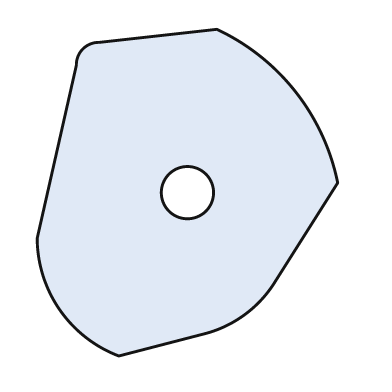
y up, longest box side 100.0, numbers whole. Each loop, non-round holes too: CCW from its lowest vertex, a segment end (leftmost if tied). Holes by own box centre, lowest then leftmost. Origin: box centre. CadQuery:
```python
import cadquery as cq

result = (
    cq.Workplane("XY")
    .moveTo(-21.0, -50.0)
    .lineTo(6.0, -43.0)
    .threePointArc((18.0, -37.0), (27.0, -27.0))
    .lineTo(46.0, 3.0)
    .threePointArc((33.0, 31.0), (9.0, 50.0))
    .lineTo(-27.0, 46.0)
    .threePointArc((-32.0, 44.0), (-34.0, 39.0))
    .lineTo(-46.0, -14.0)
    .threePointArc((-39.0, -36.0), (-21.0, -50.0))
    .close()
    .moveTo(0.0, 0.0)
    .circle(8.0)
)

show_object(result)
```